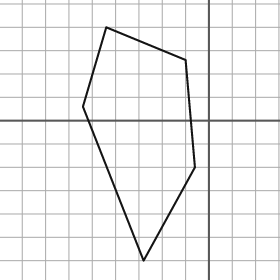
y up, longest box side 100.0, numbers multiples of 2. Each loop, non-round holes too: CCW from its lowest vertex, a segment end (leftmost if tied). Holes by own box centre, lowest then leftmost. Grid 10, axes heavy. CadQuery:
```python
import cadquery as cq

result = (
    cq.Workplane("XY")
    .moveTo(-28.0, -60.0)
    .lineTo(-6.0, -20.0)
    .lineTo(-10.0, 26.0)
    .lineTo(-44.0, 40.0)
    .lineTo(-54.0, 6.0)
    .close()
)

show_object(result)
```